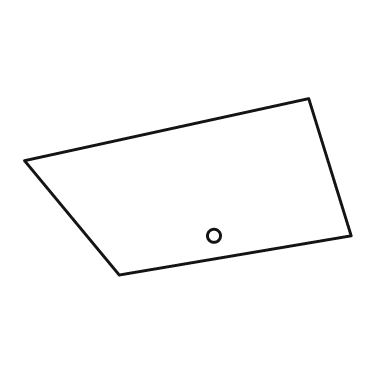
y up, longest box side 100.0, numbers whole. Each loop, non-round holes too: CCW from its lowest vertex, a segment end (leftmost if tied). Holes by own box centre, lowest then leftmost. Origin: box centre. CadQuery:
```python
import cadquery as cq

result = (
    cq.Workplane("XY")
    .moveTo(-21.0, -27.0)
    .lineTo(50.0, -15.0)
    .lineTo(37.0, 27.0)
    .lineTo(-50.0, 8.0)
    .close()
    .moveTo(8.0, -15.0)
    .circle(2.0)
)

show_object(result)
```